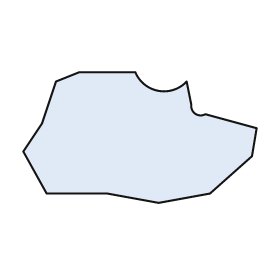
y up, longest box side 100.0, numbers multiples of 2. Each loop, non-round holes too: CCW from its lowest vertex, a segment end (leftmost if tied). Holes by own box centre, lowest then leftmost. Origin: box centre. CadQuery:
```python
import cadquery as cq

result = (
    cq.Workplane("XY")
    .moveTo(8.0, -28.0)
    .lineTo(30.0, -24.0)
    .lineTo(48.0, -8.0)
    .lineTo(50.0, 4.0)
    .lineTo(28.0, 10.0)
    .threePointArc((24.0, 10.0), (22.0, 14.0))
    .lineTo(20.0, 24.0)
    .threePointArc((8.0, 20.0), (-2.0, 28.0))
    .lineTo(-26.0, 28.0)
    .lineTo(-36.0, 24.0)
    .lineTo(-42.0, 6.0)
    .lineTo(-50.0, -6.0)
    .lineTo(-40.0, -24.0)
    .lineTo(-14.0, -24.0)
    .close()
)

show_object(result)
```